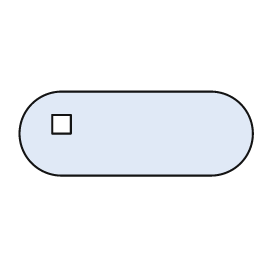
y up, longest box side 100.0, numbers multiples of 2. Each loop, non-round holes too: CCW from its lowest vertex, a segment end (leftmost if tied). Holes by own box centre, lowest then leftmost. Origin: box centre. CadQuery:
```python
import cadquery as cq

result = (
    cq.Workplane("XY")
    .moveTo(-32.0, -18.0)
    .lineTo(32.0, -18.0)
    .threePointArc((50.0, 0.0), (32.0, 18.0))
    .lineTo(-32.0, 18.0)
    .threePointArc((-50.0, 0.0), (-32.0, -18.0))
    .close()
    .moveTo(-36.0, 0.0)
    .lineTo(-28.0, 0.0)
    .lineTo(-28.0, 8.0)
    .lineTo(-36.0, 8.0)
    .close()
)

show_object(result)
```